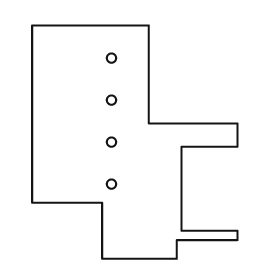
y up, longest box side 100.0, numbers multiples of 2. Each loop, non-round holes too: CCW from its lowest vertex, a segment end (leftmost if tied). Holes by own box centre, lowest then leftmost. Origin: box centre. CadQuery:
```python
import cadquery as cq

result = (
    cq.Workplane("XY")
    .moveTo(-14.0, -50.0)
    .lineTo(18.0, -50.0)
    .lineTo(18.0, -42.0)
    .lineTo(44.0, -42.0)
    .lineTo(44.0, -38.0)
    .lineTo(20.0, -38.0)
    .lineTo(20.0, -2.0)
    .lineTo(44.0, -2.0)
    .lineTo(44.0, 8.0)
    .lineTo(6.0, 8.0)
    .lineTo(6.0, 50.0)
    .lineTo(-44.0, 50.0)
    .lineTo(-44.0, -26.0)
    .lineTo(-14.0, -26.0)
    .close()
    .moveTo(-10.0, -18.0)
    .circle(2.0)
    .moveTo(-10.0, 0.0)
    .circle(2.0)
    .moveTo(-10.0, 18.0)
    .circle(2.0)
    .moveTo(-10.0, 36.0)
    .circle(2.0)
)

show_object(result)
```